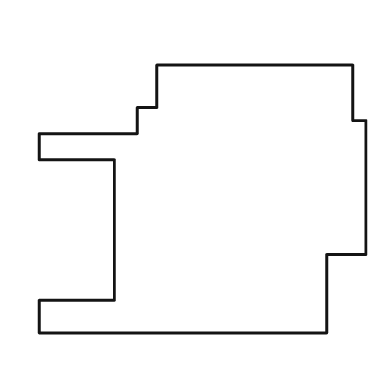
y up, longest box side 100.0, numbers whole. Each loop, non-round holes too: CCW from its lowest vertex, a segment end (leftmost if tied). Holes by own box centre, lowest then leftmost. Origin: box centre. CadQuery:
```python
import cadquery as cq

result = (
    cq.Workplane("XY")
    .moveTo(-50.0, -41.0)
    .lineTo(38.0, -41.0)
    .lineTo(38.0, -17.0)
    .lineTo(50.0, -17.0)
    .lineTo(50.0, 24.0)
    .lineTo(46.0, 24.0)
    .lineTo(46.0, 41.0)
    .lineTo(-14.0, 41.0)
    .lineTo(-14.0, 28.0)
    .lineTo(-20.0, 28.0)
    .lineTo(-20.0, 20.0)
    .lineTo(-50.0, 20.0)
    .lineTo(-50.0, 12.0)
    .lineTo(-27.0, 12.0)
    .lineTo(-27.0, -31.0)
    .lineTo(-50.0, -31.0)
    .close()
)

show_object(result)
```